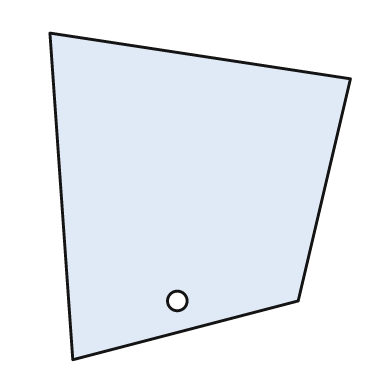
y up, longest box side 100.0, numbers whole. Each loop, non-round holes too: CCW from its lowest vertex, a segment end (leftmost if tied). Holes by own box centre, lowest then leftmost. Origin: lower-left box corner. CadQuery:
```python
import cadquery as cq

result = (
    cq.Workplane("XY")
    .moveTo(7.0, 0.0)
    .lineTo(76.0, 18.0)
    .lineTo(92.0, 86.0)
    .lineTo(0.0, 100.0)
    .close()
    .moveTo(39.0, 18.0)
    .circle(3.0)
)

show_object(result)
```